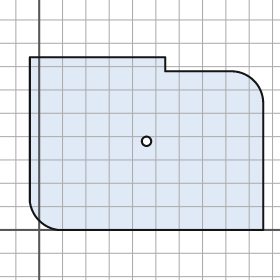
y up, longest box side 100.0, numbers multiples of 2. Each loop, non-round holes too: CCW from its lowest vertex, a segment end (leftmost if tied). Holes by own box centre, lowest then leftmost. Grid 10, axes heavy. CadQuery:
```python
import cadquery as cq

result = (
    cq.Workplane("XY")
    .moveTo(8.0, 0.0)
    .lineTo(96.0, 0.0)
    .lineTo(96.0, 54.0)
    .threePointArc((92.0, 64.0), (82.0, 68.0))
    .lineTo(54.0, 68.0)
    .lineTo(54.0, 74.0)
    .lineTo(-4.0, 74.0)
    .lineTo(-4.0, 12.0)
    .threePointArc((0.0, 4.0), (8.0, 0.0))
    .close()
    .moveTo(46.0, 38.0)
    .circle(2.0)
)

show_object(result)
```